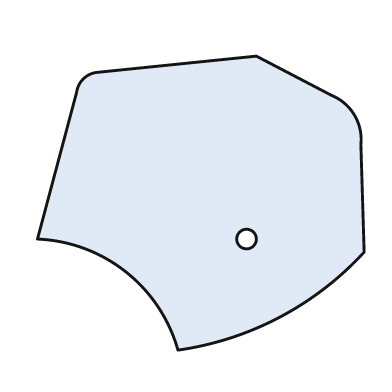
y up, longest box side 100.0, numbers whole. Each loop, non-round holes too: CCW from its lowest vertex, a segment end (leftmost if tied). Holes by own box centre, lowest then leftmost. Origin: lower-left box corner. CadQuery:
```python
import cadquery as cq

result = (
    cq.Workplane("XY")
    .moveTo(43.0, 0.0)
    .threePointArc((74.0, 10.0), (100.0, 30.0))
    .lineTo(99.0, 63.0)
    .threePointArc((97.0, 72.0), (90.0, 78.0))
    .lineTo(67.0, 90.0)
    .lineTo(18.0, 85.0)
    .threePointArc((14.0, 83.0), (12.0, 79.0))
    .lineTo(0.0, 34.0)
    .threePointArc((27.0, 24.0), (43.0, 0.0))
    .close()
    .moveTo(64.0, 34.0)
    .circle(3.0)
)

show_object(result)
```